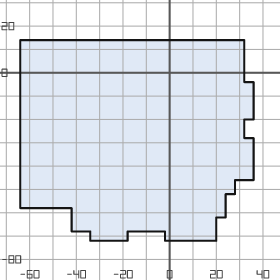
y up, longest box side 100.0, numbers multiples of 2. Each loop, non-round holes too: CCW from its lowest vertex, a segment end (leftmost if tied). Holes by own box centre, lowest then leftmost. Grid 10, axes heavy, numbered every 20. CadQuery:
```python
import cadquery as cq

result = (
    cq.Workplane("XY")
    .moveTo(-34.0, -72.0)
    .lineTo(-18.0, -72.0)
    .lineTo(-18.0, -68.0)
    .lineTo(-2.0, -68.0)
    .lineTo(-2.0, -72.0)
    .lineTo(20.0, -72.0)
    .lineTo(20.0, -62.0)
    .lineTo(24.0, -62.0)
    .lineTo(24.0, -52.0)
    .lineTo(28.0, -52.0)
    .lineTo(28.0, -46.0)
    .lineTo(36.0, -46.0)
    .lineTo(36.0, -28.0)
    .lineTo(32.0, -28.0)
    .lineTo(32.0, -20.0)
    .lineTo(36.0, -20.0)
    .lineTo(36.0, -4.0)
    .lineTo(32.0, -4.0)
    .lineTo(32.0, 14.0)
    .lineTo(-64.0, 14.0)
    .lineTo(-64.0, -58.0)
    .lineTo(-42.0, -58.0)
    .lineTo(-42.0, -68.0)
    .lineTo(-34.0, -68.0)
    .close()
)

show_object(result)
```